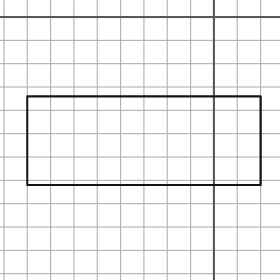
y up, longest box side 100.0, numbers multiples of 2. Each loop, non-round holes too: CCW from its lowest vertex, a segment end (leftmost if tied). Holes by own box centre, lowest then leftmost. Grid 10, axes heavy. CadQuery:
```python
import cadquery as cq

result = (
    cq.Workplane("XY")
    .moveTo(-80.0, -72.0)
    .lineTo(20.0, -72.0)
    .lineTo(20.0, -34.0)
    .lineTo(-80.0, -34.0)
    .close()
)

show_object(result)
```